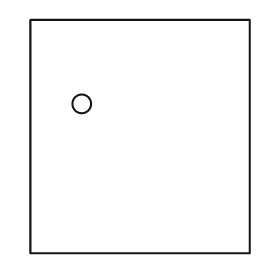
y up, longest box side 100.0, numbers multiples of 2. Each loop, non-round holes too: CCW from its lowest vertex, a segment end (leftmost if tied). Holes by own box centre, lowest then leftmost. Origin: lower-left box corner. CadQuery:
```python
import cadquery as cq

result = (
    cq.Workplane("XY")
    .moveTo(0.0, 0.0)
    .lineTo(94.0, 0.0)
    .lineTo(94.0, 100.0)
    .lineTo(0.0, 100.0)
    .close()
    .moveTo(22.0, 64.0)
    .circle(4.0)
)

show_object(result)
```